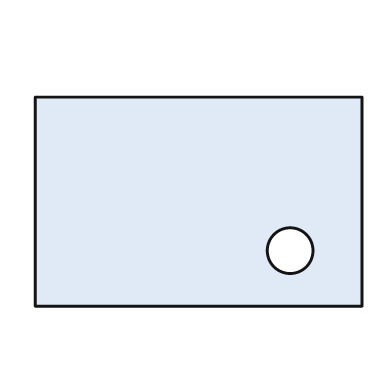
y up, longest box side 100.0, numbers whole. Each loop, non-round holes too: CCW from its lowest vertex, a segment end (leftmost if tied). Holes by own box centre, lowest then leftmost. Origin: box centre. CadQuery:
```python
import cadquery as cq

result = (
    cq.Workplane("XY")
    .moveTo(-50.0, -32.0)
    .lineTo(50.0, -32.0)
    .lineTo(50.0, 32.0)
    .lineTo(-50.0, 32.0)
    .close()
    .moveTo(28.0, -15.0)
    .circle(7.0)
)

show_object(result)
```